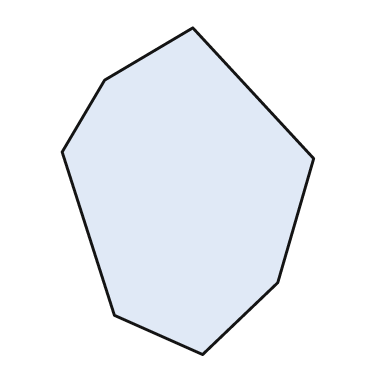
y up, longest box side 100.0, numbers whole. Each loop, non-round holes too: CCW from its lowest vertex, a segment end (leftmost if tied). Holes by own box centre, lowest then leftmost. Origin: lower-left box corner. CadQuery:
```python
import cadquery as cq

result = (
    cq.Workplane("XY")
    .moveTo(43.0, 0.0)
    .lineTo(66.0, 22.0)
    .lineTo(77.0, 60.0)
    .lineTo(40.0, 100.0)
    .lineTo(13.0, 84.0)
    .lineTo(0.0, 62.0)
    .lineTo(16.0, 12.0)
    .close()
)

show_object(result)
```